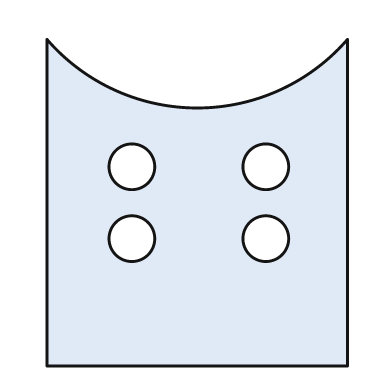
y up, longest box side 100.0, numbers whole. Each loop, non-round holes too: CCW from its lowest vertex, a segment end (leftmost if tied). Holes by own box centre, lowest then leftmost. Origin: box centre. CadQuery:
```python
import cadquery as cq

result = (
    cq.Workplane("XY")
    .moveTo(-46.0, -50.0)
    .lineTo(46.0, -50.0)
    .lineTo(46.0, 50.0)
    .threePointArc((0.0, 29.0), (-46.0, 50.0))
    .close()
    .moveTo(-20.0, -11.0)
    .circle(7.0)
    .moveTo(21.0, -11.0)
    .circle(7.0)
    .moveTo(-20.0, 11.0)
    .circle(7.0)
    .moveTo(21.0, 11.0)
    .circle(7.0)
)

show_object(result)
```